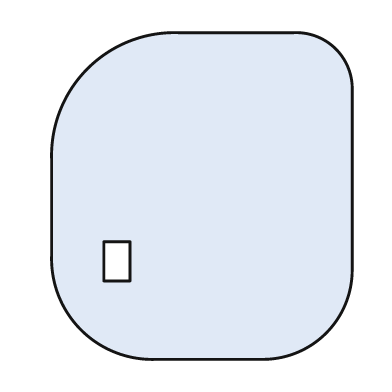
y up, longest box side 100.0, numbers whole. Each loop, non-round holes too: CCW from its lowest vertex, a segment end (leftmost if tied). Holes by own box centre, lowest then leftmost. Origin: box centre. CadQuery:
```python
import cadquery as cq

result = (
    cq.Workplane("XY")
    .moveTo(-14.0, -50.0)
    .lineTo(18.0, -50.0)
    .threePointArc((38.0, -42.0), (46.0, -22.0))
    .lineTo(46.0, 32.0)
    .threePointArc((41.0, 45.0), (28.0, 50.0))
    .lineTo(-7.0, 50.0)
    .threePointArc((-35.0, 39.0), (-46.0, 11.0))
    .lineTo(-46.0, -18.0)
    .threePointArc((-37.0, -41.0), (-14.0, -50.0))
    .close()
    .moveTo(-30.0, -26.0)
    .lineTo(-22.0, -26.0)
    .lineTo(-22.0, -14.0)
    .lineTo(-30.0, -14.0)
    .close()
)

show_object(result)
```